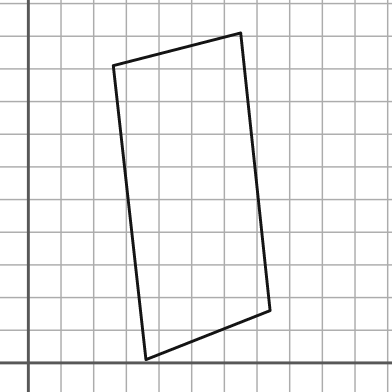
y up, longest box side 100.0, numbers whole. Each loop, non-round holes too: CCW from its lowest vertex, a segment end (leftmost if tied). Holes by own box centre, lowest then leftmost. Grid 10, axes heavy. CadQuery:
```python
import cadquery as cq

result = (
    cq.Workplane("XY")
    .moveTo(36.0, 1.0)
    .lineTo(74.0, 16.0)
    .lineTo(65.0, 101.0)
    .lineTo(26.0, 91.0)
    .close()
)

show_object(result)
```